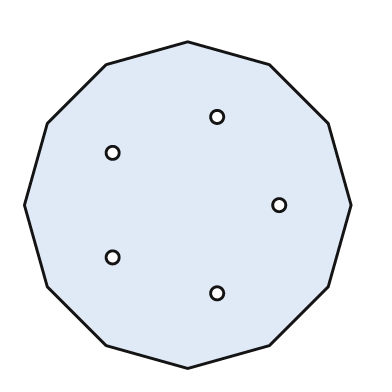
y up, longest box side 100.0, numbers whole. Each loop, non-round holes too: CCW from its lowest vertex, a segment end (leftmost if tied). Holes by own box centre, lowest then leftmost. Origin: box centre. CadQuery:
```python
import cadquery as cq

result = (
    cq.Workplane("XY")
    .moveTo(0.0, -50.0)
    .lineTo(25.0, -43.0)
    .lineTo(43.0, -25.0)
    .lineTo(50.0, 0.0)
    .lineTo(43.0, 25.0)
    .lineTo(25.0, 43.0)
    .lineTo(0.0, 50.0)
    .lineTo(-25.0, 43.0)
    .lineTo(-43.0, 25.0)
    .lineTo(-50.0, 0.0)
    .lineTo(-43.0, -25.0)
    .lineTo(-25.0, -43.0)
    .close()
    .moveTo(9.0, -27.0)
    .circle(2.0)
    .moveTo(-23.0, -16.0)
    .circle(2.0)
    .moveTo(28.0, 0.0)
    .circle(2.0)
    .moveTo(-23.0, 16.0)
    .circle(2.0)
    .moveTo(9.0, 27.0)
    .circle(2.0)
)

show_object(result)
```